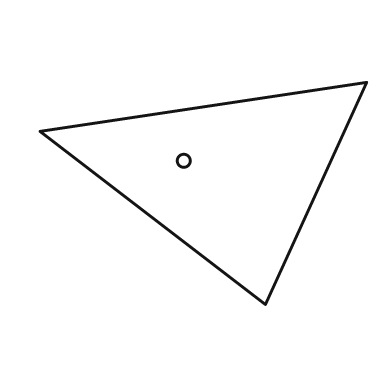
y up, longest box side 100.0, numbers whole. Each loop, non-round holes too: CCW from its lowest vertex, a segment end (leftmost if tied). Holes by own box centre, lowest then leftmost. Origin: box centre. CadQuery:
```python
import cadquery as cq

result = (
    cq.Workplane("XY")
    .moveTo(19.0, -34.0)
    .lineTo(50.0, 34.0)
    .lineTo(-50.0, 19.0)
    .close()
    .moveTo(-6.0, 10.0)
    .circle(2.0)
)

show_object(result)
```